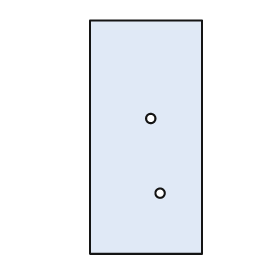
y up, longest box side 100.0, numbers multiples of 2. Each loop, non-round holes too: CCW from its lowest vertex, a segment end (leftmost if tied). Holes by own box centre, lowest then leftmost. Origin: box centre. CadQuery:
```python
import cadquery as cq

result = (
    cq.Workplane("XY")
    .moveTo(-24.0, -50.0)
    .lineTo(24.0, -50.0)
    .lineTo(24.0, 50.0)
    .lineTo(-24.0, 50.0)
    .close()
    .moveTo(6.0, -24.0)
    .circle(2.0)
    .moveTo(2.0, 8.0)
    .circle(2.0)
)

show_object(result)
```